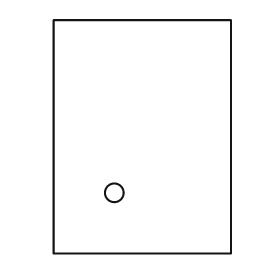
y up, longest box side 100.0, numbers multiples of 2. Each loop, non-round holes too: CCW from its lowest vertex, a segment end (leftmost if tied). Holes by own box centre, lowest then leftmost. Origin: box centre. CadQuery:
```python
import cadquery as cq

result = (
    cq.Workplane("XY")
    .moveTo(-38.0, -50.0)
    .lineTo(38.0, -50.0)
    .lineTo(38.0, 50.0)
    .lineTo(-38.0, 50.0)
    .close()
    .moveTo(-12.0, -24.0)
    .circle(4.0)
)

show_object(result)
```